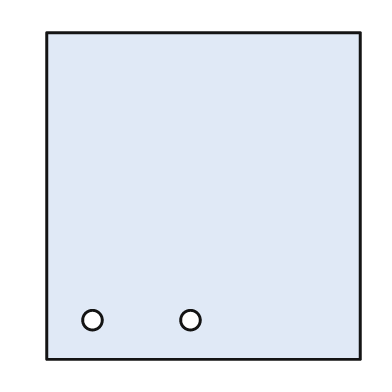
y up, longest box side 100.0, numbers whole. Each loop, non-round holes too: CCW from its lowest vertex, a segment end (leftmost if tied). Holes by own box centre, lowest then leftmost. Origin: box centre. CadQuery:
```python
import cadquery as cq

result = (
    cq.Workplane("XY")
    .moveTo(-48.0, -50.0)
    .lineTo(48.0, -50.0)
    .lineTo(48.0, 50.0)
    .lineTo(-48.0, 50.0)
    .close()
    .moveTo(-34.0, -38.0)
    .circle(3.0)
    .moveTo(-4.0, -38.0)
    .circle(3.0)
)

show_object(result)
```